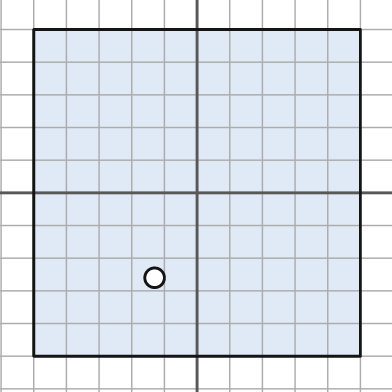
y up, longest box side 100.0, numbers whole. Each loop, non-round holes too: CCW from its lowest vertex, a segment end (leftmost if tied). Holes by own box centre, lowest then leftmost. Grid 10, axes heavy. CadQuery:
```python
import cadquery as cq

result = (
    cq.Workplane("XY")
    .moveTo(-50.0, -50.0)
    .lineTo(50.0, -50.0)
    .lineTo(50.0, 50.0)
    .lineTo(-50.0, 50.0)
    .close()
    .moveTo(-13.0, -26.0)
    .circle(3.0)
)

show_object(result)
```